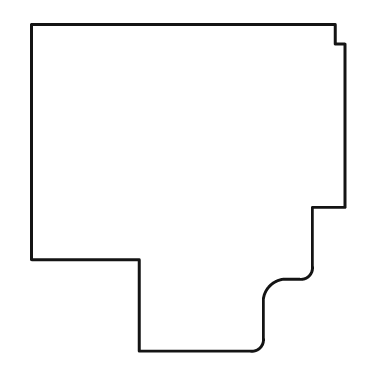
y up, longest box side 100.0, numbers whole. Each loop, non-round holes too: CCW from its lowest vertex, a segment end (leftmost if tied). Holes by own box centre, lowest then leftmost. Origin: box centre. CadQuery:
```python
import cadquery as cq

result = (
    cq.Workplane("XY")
    .moveTo(-15.0, -50.0)
    .lineTo(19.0, -50.0)
    .threePointArc((22.0, -49.0), (23.0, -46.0))
    .lineTo(23.0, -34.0)
    .threePointArc((25.0, -30.0), (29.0, -28.0))
    .lineTo(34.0, -28.0)
    .threePointArc((37.0, -27.0), (38.0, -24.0))
    .lineTo(38.0, -6.0)
    .lineTo(48.0, -6.0)
    .lineTo(48.0, 44.0)
    .lineTo(45.0, 44.0)
    .lineTo(45.0, 50.0)
    .lineTo(-48.0, 50.0)
    .lineTo(-48.0, -22.0)
    .lineTo(-15.0, -22.0)
    .close()
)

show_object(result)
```